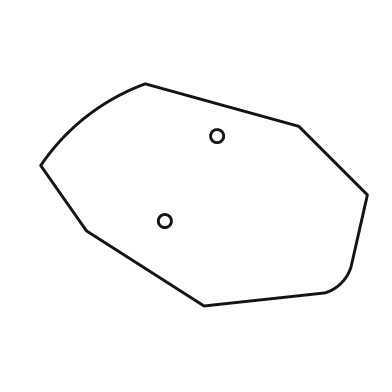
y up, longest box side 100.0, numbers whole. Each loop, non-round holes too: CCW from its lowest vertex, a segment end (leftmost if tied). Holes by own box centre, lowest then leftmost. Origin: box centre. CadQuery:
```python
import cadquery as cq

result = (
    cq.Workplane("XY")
    .moveTo(0.0, -34.0)
    .lineTo(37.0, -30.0)
    .threePointArc((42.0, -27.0), (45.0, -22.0))
    .lineTo(50.0, 0.0)
    .lineTo(29.0, 21.0)
    .lineTo(-18.0, 34.0)
    .threePointArc((-36.0, 24.0), (-50.0, 9.0))
    .lineTo(-36.0, -11.0)
    .close()
    .moveTo(-12.0, -8.0)
    .circle(2.0)
    .moveTo(4.0, 18.0)
    .circle(2.0)
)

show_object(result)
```